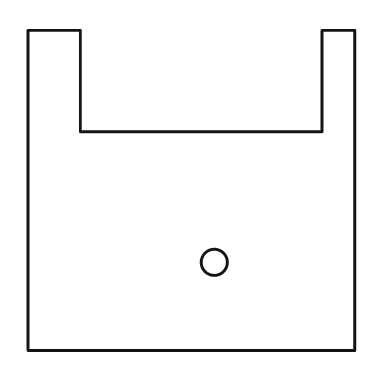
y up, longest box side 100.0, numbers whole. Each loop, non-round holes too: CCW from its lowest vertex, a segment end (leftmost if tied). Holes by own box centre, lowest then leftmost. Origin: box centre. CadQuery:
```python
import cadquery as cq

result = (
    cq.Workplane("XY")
    .moveTo(-50.0, -49.0)
    .lineTo(50.0, -49.0)
    .lineTo(50.0, 49.0)
    .lineTo(40.0, 49.0)
    .lineTo(40.0, 18.0)
    .lineTo(-34.0, 18.0)
    .lineTo(-34.0, 49.0)
    .lineTo(-50.0, 49.0)
    .close()
    .moveTo(7.0, -22.0)
    .circle(4.0)
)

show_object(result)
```